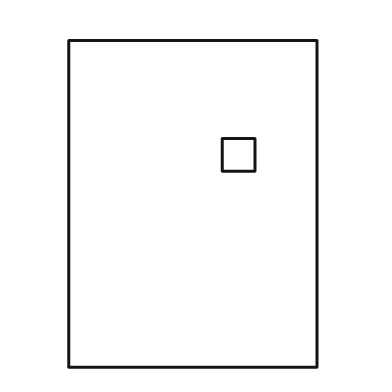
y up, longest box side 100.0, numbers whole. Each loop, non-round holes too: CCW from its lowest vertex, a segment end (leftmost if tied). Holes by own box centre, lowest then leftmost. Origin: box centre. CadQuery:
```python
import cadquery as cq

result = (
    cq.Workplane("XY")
    .moveTo(-38.0, -50.0)
    .lineTo(38.0, -50.0)
    .lineTo(38.0, 50.0)
    .lineTo(-38.0, 50.0)
    .close()
    .moveTo(9.0, 10.0)
    .lineTo(19.0, 10.0)
    .lineTo(19.0, 20.0)
    .lineTo(9.0, 20.0)
    .close()
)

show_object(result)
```